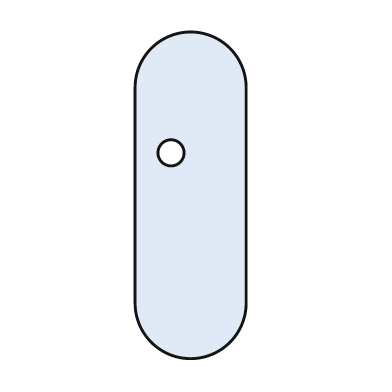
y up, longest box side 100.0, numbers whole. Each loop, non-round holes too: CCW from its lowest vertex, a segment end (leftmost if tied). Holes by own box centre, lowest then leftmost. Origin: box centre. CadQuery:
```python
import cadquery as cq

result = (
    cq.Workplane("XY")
    .moveTo(-17.0, -33.0)
    .threePointArc((0.0, -50.0), (17.0, -33.0))
    .lineTo(17.0, 33.0)
    .threePointArc((0.0, 50.0), (-17.0, 33.0))
    .close()
    .moveTo(-6.0, 13.0)
    .circle(4.0)
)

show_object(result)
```